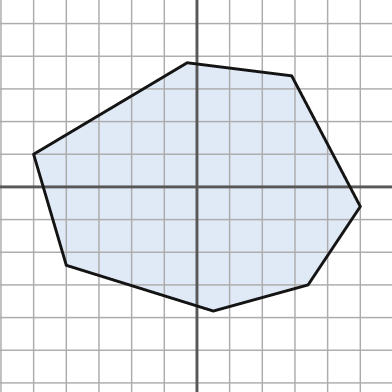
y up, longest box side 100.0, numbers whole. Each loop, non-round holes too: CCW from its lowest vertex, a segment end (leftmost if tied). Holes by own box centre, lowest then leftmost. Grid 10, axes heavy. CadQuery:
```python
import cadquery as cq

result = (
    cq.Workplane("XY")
    .moveTo(5.0, -38.0)
    .lineTo(34.0, -30.0)
    .lineTo(50.0, -6.0)
    .lineTo(29.0, 34.0)
    .lineTo(-3.0, 38.0)
    .lineTo(-50.0, 10.0)
    .lineTo(-40.0, -24.0)
    .close()
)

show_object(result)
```